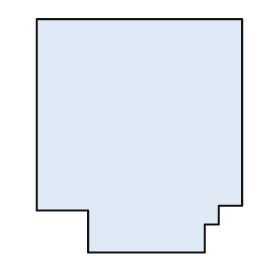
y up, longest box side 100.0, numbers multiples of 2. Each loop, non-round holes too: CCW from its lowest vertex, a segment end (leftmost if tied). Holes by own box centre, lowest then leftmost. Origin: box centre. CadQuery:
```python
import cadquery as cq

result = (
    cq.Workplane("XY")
    .moveTo(-22.0, -50.0)
    .lineTo(28.0, -50.0)
    .lineTo(28.0, -38.0)
    .lineTo(34.0, -38.0)
    .lineTo(34.0, -30.0)
    .lineTo(44.0, -30.0)
    .lineTo(44.0, 50.0)
    .lineTo(-44.0, 50.0)
    .lineTo(-44.0, -32.0)
    .lineTo(-22.0, -32.0)
    .close()
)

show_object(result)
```